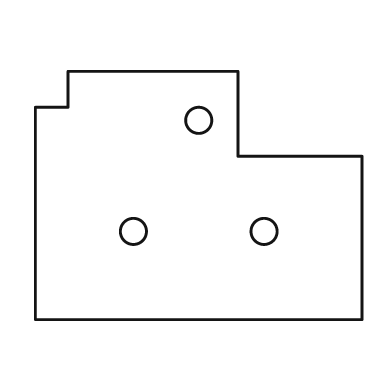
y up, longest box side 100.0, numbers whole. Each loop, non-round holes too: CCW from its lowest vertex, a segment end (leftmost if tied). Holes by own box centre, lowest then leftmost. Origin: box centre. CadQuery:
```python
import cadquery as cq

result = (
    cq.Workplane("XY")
    .moveTo(-50.0, -38.0)
    .lineTo(50.0, -38.0)
    .lineTo(50.0, 12.0)
    .lineTo(12.0, 12.0)
    .lineTo(12.0, 38.0)
    .lineTo(-40.0, 38.0)
    .lineTo(-40.0, 27.0)
    .lineTo(-50.0, 27.0)
    .close()
    .moveTo(-20.0, -11.0)
    .circle(4.0)
    .moveTo(20.0, -11.0)
    .circle(4.0)
    .moveTo(0.0, 23.0)
    .circle(4.0)
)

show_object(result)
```